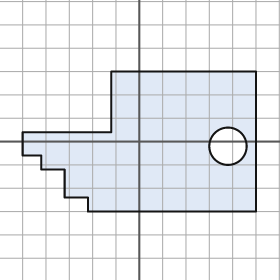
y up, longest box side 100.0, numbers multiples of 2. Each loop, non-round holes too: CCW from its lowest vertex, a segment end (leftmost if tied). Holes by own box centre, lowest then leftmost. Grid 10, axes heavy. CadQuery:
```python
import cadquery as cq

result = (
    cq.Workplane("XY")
    .moveTo(-22.0, -30.0)
    .lineTo(50.0, -30.0)
    .lineTo(50.0, 30.0)
    .lineTo(-12.0, 30.0)
    .lineTo(-12.0, 4.0)
    .lineTo(-50.0, 4.0)
    .lineTo(-50.0, -6.0)
    .lineTo(-42.0, -6.0)
    .lineTo(-42.0, -12.0)
    .lineTo(-32.0, -12.0)
    .lineTo(-32.0, -24.0)
    .lineTo(-22.0, -24.0)
    .close()
    .moveTo(38.0, -2.0)
    .circle(8.0)
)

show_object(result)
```